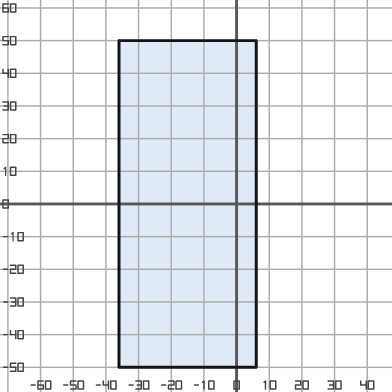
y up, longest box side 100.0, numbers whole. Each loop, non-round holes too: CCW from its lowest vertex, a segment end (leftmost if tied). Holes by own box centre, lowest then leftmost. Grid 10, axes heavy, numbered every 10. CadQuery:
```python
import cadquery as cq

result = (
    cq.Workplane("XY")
    .moveTo(-36.0, -50.0)
    .lineTo(6.0, -50.0)
    .lineTo(6.0, 50.0)
    .lineTo(-36.0, 50.0)
    .close()
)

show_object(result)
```